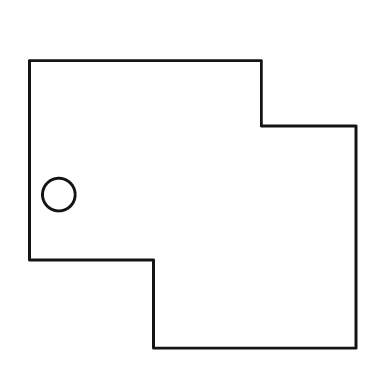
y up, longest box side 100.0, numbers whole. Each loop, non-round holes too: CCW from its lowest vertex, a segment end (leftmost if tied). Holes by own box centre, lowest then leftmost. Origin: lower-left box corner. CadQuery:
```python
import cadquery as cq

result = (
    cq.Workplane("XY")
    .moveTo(38.0, 0.0)
    .lineTo(100.0, 0.0)
    .lineTo(100.0, 68.0)
    .lineTo(71.0, 68.0)
    .lineTo(71.0, 88.0)
    .lineTo(0.0, 88.0)
    .lineTo(0.0, 27.0)
    .lineTo(38.0, 27.0)
    .close()
    .moveTo(9.0, 47.0)
    .circle(5.0)
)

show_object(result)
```